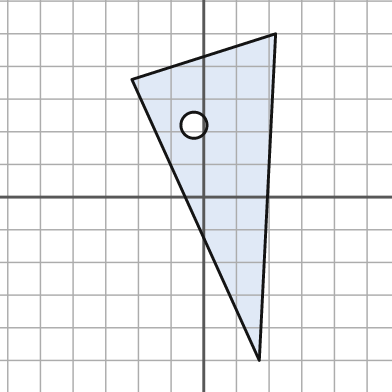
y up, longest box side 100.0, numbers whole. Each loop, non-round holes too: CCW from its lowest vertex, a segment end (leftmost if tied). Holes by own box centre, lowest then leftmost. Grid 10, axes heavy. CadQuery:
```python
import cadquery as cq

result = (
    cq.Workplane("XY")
    .moveTo(17.0, -50.0)
    .lineTo(22.0, 50.0)
    .lineTo(-22.0, 36.0)
    .close()
    .moveTo(-3.0, 22.0)
    .circle(4.0)
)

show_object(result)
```